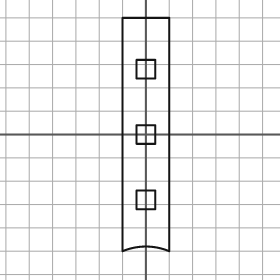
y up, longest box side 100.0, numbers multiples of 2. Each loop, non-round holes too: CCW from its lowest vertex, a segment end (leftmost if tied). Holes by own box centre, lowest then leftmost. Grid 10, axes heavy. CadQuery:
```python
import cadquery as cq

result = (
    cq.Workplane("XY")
    .moveTo(-10.0, -50.0)
    .threePointArc((0.0, -48.0), (10.0, -50.0))
    .lineTo(10.0, 50.0)
    .lineTo(-10.0, 50.0)
    .close()
    .moveTo(-4.0, -32.0)
    .lineTo(4.0, -32.0)
    .lineTo(4.0, -24.0)
    .lineTo(-4.0, -24.0)
    .close()
    .moveTo(-4.0, -4.0)
    .lineTo(4.0, -4.0)
    .lineTo(4.0, 4.0)
    .lineTo(-4.0, 4.0)
    .close()
    .moveTo(-4.0, 24.0)
    .lineTo(4.0, 24.0)
    .lineTo(4.0, 32.0)
    .lineTo(-4.0, 32.0)
    .close()
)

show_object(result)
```